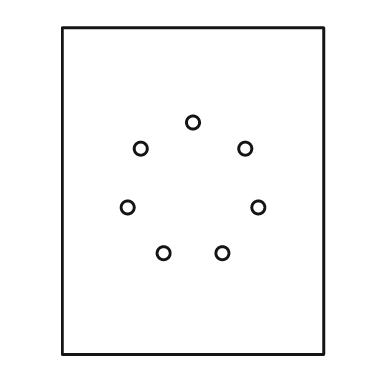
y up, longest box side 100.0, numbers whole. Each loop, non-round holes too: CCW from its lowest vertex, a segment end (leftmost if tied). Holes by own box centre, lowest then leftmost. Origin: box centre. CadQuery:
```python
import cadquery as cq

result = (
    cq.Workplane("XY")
    .moveTo(-40.0, -50.0)
    .lineTo(40.0, -50.0)
    .lineTo(40.0, 50.0)
    .lineTo(-40.0, 50.0)
    .close()
    .moveTo(-9.0, -19.0)
    .circle(2.0)
    .moveTo(9.0, -19.0)
    .circle(2.0)
    .moveTo(-20.0, -5.0)
    .circle(2.0)
    .moveTo(20.0, -5.0)
    .circle(2.0)
    .moveTo(-16.0, 13.0)
    .circle(2.0)
    .moveTo(16.0, 13.0)
    .circle(2.0)
    .moveTo(0.0, 21.0)
    .circle(2.0)
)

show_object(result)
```